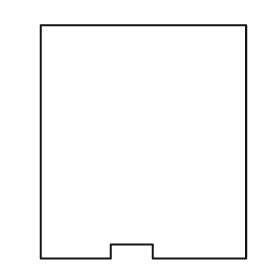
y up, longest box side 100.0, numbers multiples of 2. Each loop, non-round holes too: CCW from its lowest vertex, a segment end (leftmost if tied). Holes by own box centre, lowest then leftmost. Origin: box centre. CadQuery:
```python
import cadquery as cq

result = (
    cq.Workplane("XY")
    .moveTo(-44.0, -50.0)
    .lineTo(-14.0, -50.0)
    .lineTo(-14.0, -44.0)
    .lineTo(4.0, -44.0)
    .lineTo(4.0, -50.0)
    .lineTo(44.0, -50.0)
    .lineTo(44.0, 50.0)
    .lineTo(-44.0, 50.0)
    .close()
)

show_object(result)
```